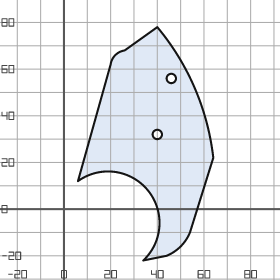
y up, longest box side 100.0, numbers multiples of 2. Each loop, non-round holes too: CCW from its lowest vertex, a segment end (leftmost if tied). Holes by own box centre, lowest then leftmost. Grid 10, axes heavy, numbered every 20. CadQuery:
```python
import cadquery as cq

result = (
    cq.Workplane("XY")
    .moveTo(34.0, -22.0)
    .lineTo(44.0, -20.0)
    .threePointArc((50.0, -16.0), (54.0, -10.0))
    .lineTo(64.0, 22.0)
    .threePointArc((56.0, 52.0), (40.0, 78.0))
    .lineTo(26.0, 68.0)
    .threePointArc((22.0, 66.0), (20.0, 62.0))
    .lineTo(6.0, 12.0)
    .threePointArc((36.0, 8.0), (34.0, -22.0))
    .close()
    .moveTo(40.0, 32.0)
    .circle(2.0)
    .moveTo(46.0, 56.0)
    .circle(2.0)
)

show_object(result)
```